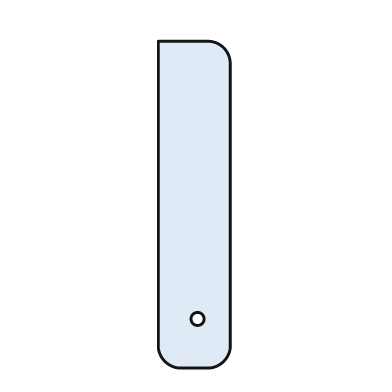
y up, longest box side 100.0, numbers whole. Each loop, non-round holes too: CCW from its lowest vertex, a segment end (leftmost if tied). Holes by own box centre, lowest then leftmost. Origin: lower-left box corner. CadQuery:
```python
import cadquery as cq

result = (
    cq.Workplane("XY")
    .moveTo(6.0, 0.0)
    .lineTo(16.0, 0.0)
    .threePointArc((20.0, 2.0), (22.0, 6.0))
    .lineTo(22.0, 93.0)
    .threePointArc((20.0, 98.0), (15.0, 100.0))
    .lineTo(0.0, 100.0)
    .lineTo(0.0, 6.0)
    .threePointArc((2.0, 2.0), (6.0, 0.0))
    .close()
    .moveTo(12.0, 15.0)
    .circle(2.0)
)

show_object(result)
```